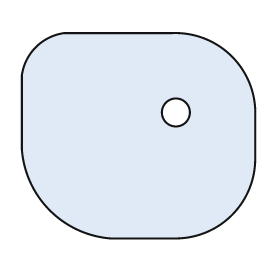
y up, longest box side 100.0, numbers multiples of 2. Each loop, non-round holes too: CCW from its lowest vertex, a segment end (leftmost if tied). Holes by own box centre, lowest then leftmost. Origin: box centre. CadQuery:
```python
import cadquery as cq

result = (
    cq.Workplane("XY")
    .moveTo(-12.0, -44.0)
    .lineTo(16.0, -44.0)
    .threePointArc((40.0, -34.0), (50.0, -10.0))
    .lineTo(50.0, 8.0)
    .threePointArc((40.0, 34.0), (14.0, 44.0))
    .lineTo(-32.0, 44.0)
    .threePointArc((-44.0, 38.0), (-50.0, 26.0))
    .lineTo(-50.0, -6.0)
    .threePointArc((-38.0, -32.0), (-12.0, -44.0))
    .close()
    .moveTo(16.0, 10.0)
    .circle(6.0)
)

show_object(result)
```